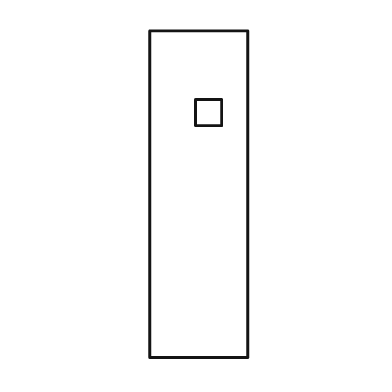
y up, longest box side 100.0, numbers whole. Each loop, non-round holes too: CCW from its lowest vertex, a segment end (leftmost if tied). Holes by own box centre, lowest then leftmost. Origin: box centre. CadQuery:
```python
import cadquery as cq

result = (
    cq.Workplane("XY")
    .moveTo(-15.0, -50.0)
    .lineTo(15.0, -50.0)
    .lineTo(15.0, 50.0)
    .lineTo(-15.0, 50.0)
    .close()
    .moveTo(-1.0, 21.0)
    .lineTo(7.0, 21.0)
    .lineTo(7.0, 29.0)
    .lineTo(-1.0, 29.0)
    .close()
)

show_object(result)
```